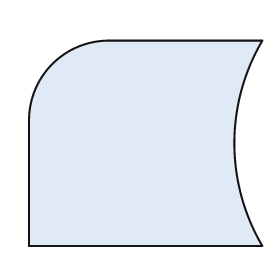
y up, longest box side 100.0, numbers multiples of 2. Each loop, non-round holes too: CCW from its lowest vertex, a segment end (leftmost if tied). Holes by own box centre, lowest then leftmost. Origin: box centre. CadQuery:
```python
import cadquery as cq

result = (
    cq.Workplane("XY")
    .moveTo(-50.0, -44.0)
    .lineTo(50.0, -44.0)
    .threePointArc((38.0, 0.0), (50.0, 44.0))
    .lineTo(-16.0, 44.0)
    .threePointArc((-40.0, 34.0), (-50.0, 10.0))
    .close()
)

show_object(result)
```